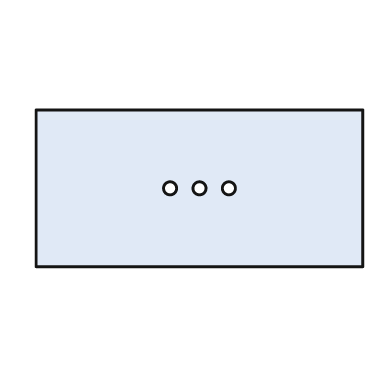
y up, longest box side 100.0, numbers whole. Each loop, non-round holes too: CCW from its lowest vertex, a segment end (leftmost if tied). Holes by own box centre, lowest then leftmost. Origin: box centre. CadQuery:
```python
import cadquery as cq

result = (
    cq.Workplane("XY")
    .moveTo(-50.0, -24.0)
    .lineTo(50.0, -24.0)
    .lineTo(50.0, 24.0)
    .lineTo(-50.0, 24.0)
    .close()
    .moveTo(-9.0, 0.0)
    .circle(2.0)
    .moveTo(0.0, 0.0)
    .circle(2.0)
    .moveTo(9.0, 0.0)
    .circle(2.0)
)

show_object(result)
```